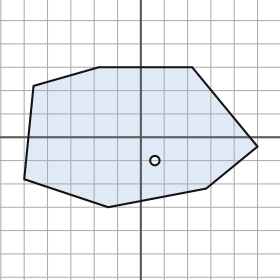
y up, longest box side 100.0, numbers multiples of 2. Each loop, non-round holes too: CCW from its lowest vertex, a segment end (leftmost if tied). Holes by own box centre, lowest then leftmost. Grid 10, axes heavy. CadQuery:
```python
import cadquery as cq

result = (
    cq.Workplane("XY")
    .moveTo(-14.0, -30.0)
    .lineTo(28.0, -22.0)
    .lineTo(50.0, -4.0)
    .lineTo(22.0, 30.0)
    .lineTo(-18.0, 30.0)
    .lineTo(-46.0, 22.0)
    .lineTo(-50.0, -18.0)
    .close()
    .moveTo(6.0, -10.0)
    .circle(2.0)
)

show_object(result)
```